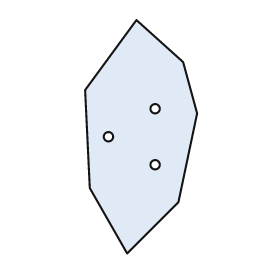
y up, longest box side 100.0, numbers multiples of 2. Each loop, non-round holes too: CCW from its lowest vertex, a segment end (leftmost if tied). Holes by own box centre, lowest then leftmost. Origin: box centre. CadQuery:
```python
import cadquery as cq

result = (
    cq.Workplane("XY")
    .moveTo(-6.0, -50.0)
    .lineTo(16.0, -28.0)
    .lineTo(24.0, 10.0)
    .lineTo(18.0, 32.0)
    .lineTo(-2.0, 50.0)
    .lineTo(-24.0, 20.0)
    .lineTo(-22.0, -22.0)
    .close()
    .moveTo(6.0, -12.0)
    .circle(2.0)
    .moveTo(-14.0, 0.0)
    .circle(2.0)
    .moveTo(6.0, 12.0)
    .circle(2.0)
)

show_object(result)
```